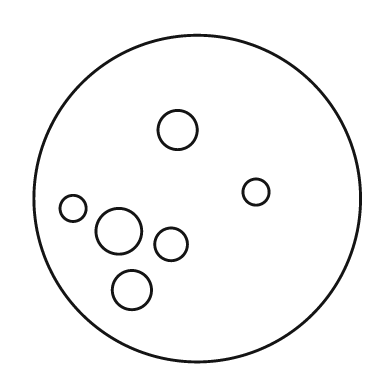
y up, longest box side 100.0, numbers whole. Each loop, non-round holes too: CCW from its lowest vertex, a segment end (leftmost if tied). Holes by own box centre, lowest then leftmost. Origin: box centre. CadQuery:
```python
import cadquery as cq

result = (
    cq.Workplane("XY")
    .moveTo(0.0, 0.0)
    .circle(50.0)
    .moveTo(-20.0, -28.0)
    .circle(6.0)
    .moveTo(-8.0, -14.0)
    .circle(5.0)
    .moveTo(-24.0, -10.0)
    .circle(7.0)
    .moveTo(-38.0, -3.0)
    .circle(4.0)
    .moveTo(18.0, 2.0)
    .circle(4.0)
    .moveTo(-6.0, 21.0)
    .circle(6.0)
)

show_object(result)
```